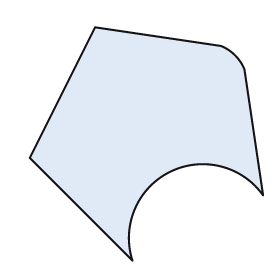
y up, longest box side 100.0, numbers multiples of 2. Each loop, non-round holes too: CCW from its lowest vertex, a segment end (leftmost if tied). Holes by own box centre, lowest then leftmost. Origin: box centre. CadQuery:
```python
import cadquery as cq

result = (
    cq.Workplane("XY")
    .moveTo(-6.0, -50.0)
    .threePointArc((10.0, -12.0), (50.0, -22.0))
    .lineTo(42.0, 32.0)
    .threePointArc((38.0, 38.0), (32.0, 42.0))
    .lineTo(-22.0, 50.0)
    .lineTo(-50.0, -6.0)
    .close()
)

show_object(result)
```